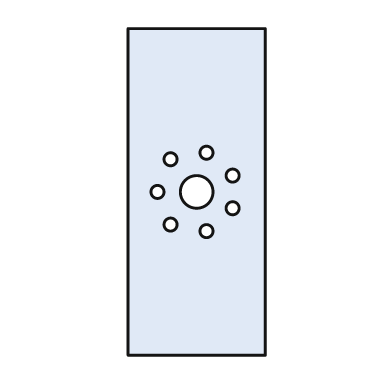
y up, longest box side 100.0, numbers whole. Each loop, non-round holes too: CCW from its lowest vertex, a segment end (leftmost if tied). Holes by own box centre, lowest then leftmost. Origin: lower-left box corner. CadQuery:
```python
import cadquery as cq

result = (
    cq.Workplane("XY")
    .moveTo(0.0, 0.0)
    .lineTo(42.0, 0.0)
    .lineTo(42.0, 100.0)
    .lineTo(0.0, 100.0)
    .close()
    .moveTo(24.0, 38.0)
    .circle(2.0)
    .moveTo(13.0, 40.0)
    .circle(2.0)
    .moveTo(32.0, 45.0)
    .circle(2.0)
    .moveTo(9.0, 50.0)
    .circle(2.0)
    .moveTo(21.0, 50.0)
    .circle(5.0)
    .moveTo(32.0, 55.0)
    .circle(2.0)
    .moveTo(13.0, 60.0)
    .circle(2.0)
    .moveTo(24.0, 62.0)
    .circle(2.0)
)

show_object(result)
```